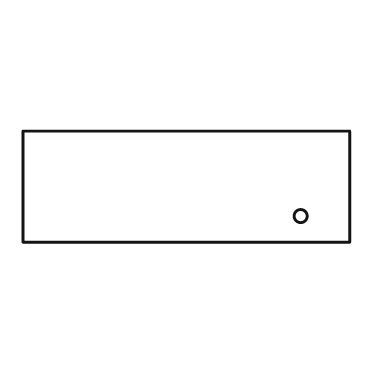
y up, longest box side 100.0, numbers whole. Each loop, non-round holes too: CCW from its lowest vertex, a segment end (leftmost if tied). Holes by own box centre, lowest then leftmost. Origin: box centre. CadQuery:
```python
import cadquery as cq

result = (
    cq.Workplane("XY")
    .moveTo(-50.0, -17.0)
    .lineTo(50.0, -17.0)
    .lineTo(50.0, 17.0)
    .lineTo(-50.0, 17.0)
    .close()
    .moveTo(35.0, -9.0)
    .circle(2.0)
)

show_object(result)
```